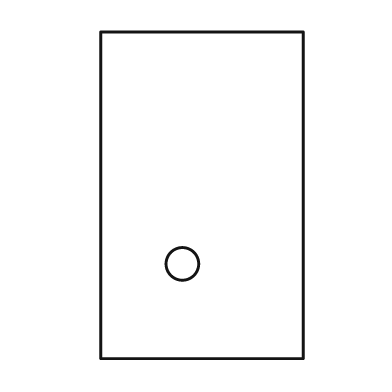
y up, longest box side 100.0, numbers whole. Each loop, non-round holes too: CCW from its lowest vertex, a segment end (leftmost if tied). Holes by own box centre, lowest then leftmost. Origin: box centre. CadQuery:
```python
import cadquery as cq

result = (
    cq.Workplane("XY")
    .moveTo(-31.0, -50.0)
    .lineTo(31.0, -50.0)
    .lineTo(31.0, 50.0)
    .lineTo(-31.0, 50.0)
    .close()
    .moveTo(-6.0, -21.0)
    .circle(5.0)
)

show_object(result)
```